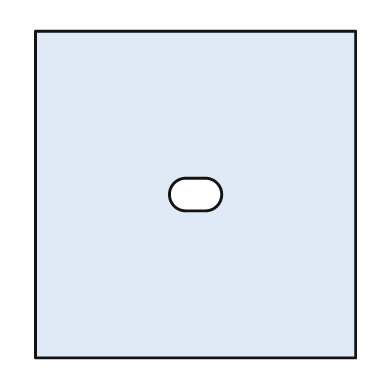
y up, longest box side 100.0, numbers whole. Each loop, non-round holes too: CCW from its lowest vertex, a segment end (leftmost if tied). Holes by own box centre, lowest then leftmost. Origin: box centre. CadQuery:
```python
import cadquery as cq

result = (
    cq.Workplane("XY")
    .moveTo(-49.0, -50.0)
    .lineTo(49.0, -50.0)
    .lineTo(49.0, 50.0)
    .lineTo(-49.0, 50.0)
    .close()
    .moveTo(-3.0, -5.0)
    .lineTo(3.0, -5.0)
    .threePointArc((8.0, 0.0), (3.0, 5.0))
    .lineTo(-3.0, 5.0)
    .threePointArc((-8.0, 0.0), (-3.0, -5.0))
    .close()
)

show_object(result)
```